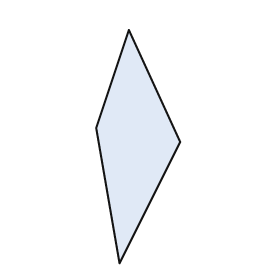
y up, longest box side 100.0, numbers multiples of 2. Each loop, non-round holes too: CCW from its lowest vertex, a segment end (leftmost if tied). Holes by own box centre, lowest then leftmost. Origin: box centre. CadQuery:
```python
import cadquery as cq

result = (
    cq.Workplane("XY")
    .moveTo(-8.0, -50.0)
    .lineTo(18.0, 2.0)
    .lineTo(-4.0, 50.0)
    .lineTo(-18.0, 8.0)
    .close()
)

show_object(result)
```